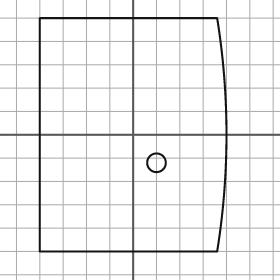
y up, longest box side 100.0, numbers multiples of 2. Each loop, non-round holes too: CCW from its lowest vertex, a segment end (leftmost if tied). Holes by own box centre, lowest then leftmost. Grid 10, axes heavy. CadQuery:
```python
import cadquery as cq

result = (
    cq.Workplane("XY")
    .moveTo(-40.0, -50.0)
    .lineTo(36.0, -50.0)
    .threePointArc((40.0, 0.0), (36.0, 50.0))
    .lineTo(-40.0, 50.0)
    .close()
    .moveTo(10.0, -12.0)
    .circle(4.0)
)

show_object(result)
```